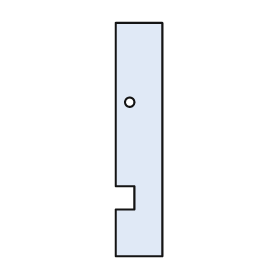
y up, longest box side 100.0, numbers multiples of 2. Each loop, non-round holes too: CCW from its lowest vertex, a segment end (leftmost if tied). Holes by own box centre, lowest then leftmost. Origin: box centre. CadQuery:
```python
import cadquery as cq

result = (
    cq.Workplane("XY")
    .moveTo(-10.0, -50.0)
    .lineTo(10.0, -50.0)
    .lineTo(10.0, 50.0)
    .lineTo(-10.0, 50.0)
    .lineTo(-10.0, -20.0)
    .lineTo(-2.0, -20.0)
    .lineTo(-2.0, -30.0)
    .lineTo(-10.0, -30.0)
    .close()
    .moveTo(-4.0, 16.0)
    .circle(2.0)
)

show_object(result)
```